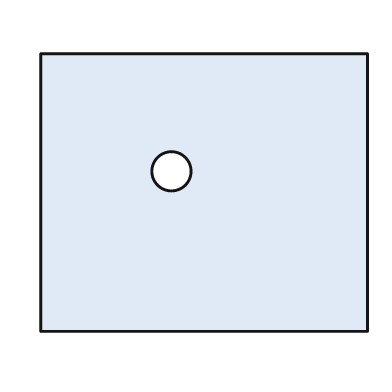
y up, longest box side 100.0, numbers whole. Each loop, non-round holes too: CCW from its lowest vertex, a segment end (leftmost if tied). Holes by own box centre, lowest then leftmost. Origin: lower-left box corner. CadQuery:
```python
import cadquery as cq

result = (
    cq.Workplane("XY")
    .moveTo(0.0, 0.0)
    .lineTo(100.0, 0.0)
    .lineTo(100.0, 85.0)
    .lineTo(0.0, 85.0)
    .close()
    .moveTo(40.0, 49.0)
    .circle(6.0)
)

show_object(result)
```